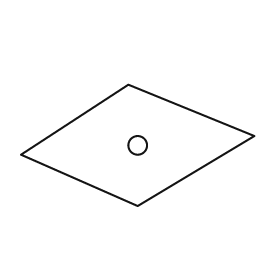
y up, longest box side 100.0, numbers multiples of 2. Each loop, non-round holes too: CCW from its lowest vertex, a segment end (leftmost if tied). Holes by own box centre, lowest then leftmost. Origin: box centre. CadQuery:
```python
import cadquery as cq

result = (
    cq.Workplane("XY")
    .moveTo(0.0, -26.0)
    .lineTo(50.0, 4.0)
    .lineTo(-4.0, 26.0)
    .lineTo(-50.0, -4.0)
    .close()
    .moveTo(0.0, 0.0)
    .circle(4.0)
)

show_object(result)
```